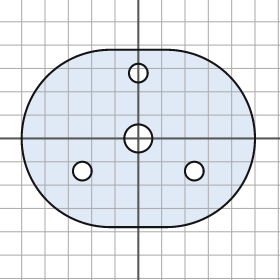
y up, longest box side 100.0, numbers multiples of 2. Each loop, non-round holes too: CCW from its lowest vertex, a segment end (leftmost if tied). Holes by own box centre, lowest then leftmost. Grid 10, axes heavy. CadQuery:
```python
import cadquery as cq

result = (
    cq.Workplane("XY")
    .moveTo(-12.0, -38.0)
    .lineTo(12.0, -38.0)
    .threePointArc((50.0, 0.0), (12.0, 38.0))
    .lineTo(-12.0, 38.0)
    .threePointArc((-50.0, 0.0), (-12.0, -38.0))
    .close()
    .moveTo(-24.0, -14.0)
    .circle(4.0)
    .moveTo(24.0, -14.0)
    .circle(4.0)
    .moveTo(0.0, 0.0)
    .circle(6.0)
    .moveTo(0.0, 28.0)
    .circle(4.0)
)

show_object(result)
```